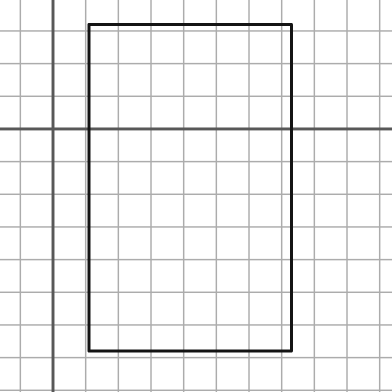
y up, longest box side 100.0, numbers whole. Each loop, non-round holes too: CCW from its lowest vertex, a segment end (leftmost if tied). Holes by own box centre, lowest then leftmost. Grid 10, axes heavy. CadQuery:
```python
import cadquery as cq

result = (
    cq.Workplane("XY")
    .moveTo(11.0, -68.0)
    .lineTo(73.0, -68.0)
    .lineTo(73.0, 32.0)
    .lineTo(11.0, 32.0)
    .close()
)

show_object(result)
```